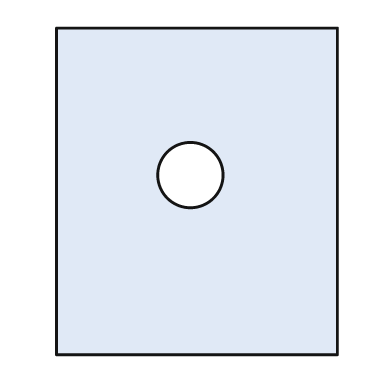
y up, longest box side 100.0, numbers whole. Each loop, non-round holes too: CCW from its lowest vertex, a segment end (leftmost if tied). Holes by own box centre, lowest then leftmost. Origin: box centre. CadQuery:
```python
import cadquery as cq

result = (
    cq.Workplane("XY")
    .moveTo(-43.0, -50.0)
    .lineTo(43.0, -50.0)
    .lineTo(43.0, 50.0)
    .lineTo(-43.0, 50.0)
    .close()
    .moveTo(-2.0, 5.0)
    .circle(10.0)
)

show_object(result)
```